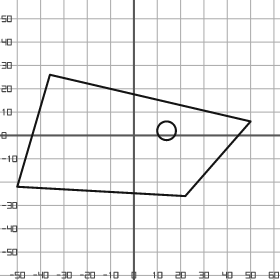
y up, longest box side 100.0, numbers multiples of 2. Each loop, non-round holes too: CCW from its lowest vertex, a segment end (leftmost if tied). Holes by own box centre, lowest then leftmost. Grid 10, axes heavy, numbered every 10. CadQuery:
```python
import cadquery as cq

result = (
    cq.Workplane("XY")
    .moveTo(22.0, -26.0)
    .lineTo(50.0, 6.0)
    .lineTo(-36.0, 26.0)
    .lineTo(-50.0, -22.0)
    .close()
    .moveTo(14.0, 2.0)
    .circle(4.0)
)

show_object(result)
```